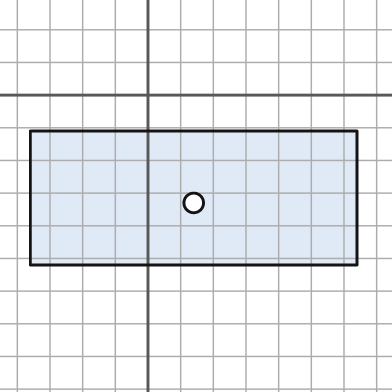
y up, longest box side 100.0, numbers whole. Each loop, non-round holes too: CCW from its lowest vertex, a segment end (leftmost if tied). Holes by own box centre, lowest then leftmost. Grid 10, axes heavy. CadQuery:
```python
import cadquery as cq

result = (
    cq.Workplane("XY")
    .moveTo(-36.0, -52.0)
    .lineTo(64.0, -52.0)
    .lineTo(64.0, -11.0)
    .lineTo(-36.0, -11.0)
    .close()
    .moveTo(14.0, -33.0)
    .circle(3.0)
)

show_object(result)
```